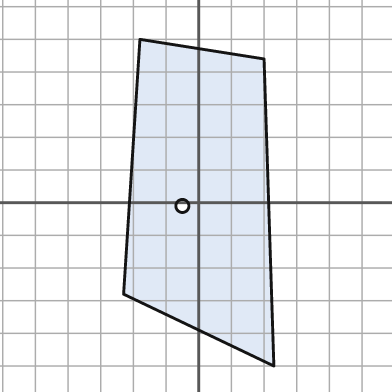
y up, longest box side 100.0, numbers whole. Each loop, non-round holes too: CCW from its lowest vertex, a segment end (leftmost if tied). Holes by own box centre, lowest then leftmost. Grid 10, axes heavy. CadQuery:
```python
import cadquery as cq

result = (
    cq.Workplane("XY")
    .moveTo(23.0, -50.0)
    .lineTo(20.0, 44.0)
    .lineTo(-18.0, 50.0)
    .lineTo(-23.0, -28.0)
    .close()
    .moveTo(-5.0, -1.0)
    .circle(2.0)
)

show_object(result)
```